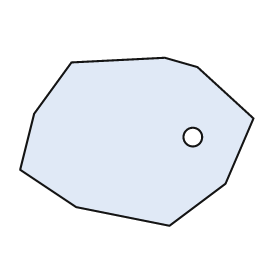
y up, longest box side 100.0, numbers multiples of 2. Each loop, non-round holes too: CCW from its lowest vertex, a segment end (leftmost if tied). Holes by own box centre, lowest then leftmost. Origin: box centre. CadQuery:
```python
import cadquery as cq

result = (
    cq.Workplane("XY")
    .moveTo(14.0, -36.0)
    .lineTo(38.0, -18.0)
    .lineTo(50.0, 10.0)
    .lineTo(26.0, 32.0)
    .lineTo(12.0, 36.0)
    .lineTo(-28.0, 34.0)
    .lineTo(-44.0, 12.0)
    .lineTo(-50.0, -12.0)
    .lineTo(-26.0, -28.0)
    .close()
    .moveTo(24.0, 2.0)
    .circle(4.0)
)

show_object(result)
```